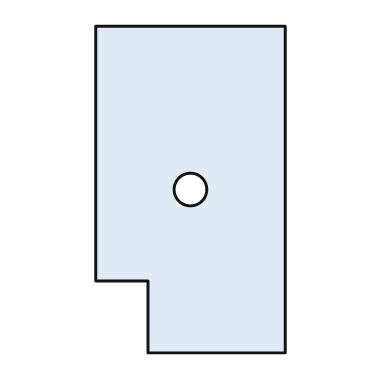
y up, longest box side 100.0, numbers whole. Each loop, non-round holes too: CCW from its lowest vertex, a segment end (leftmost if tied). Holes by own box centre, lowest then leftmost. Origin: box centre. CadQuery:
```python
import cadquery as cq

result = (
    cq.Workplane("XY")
    .moveTo(-13.0, -50.0)
    .lineTo(29.0, -50.0)
    .lineTo(29.0, 50.0)
    .lineTo(-29.0, 50.0)
    .lineTo(-29.0, -28.0)
    .lineTo(-13.0, -28.0)
    .close()
    .moveTo(0.0, 0.0)
    .circle(5.0)
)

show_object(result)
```